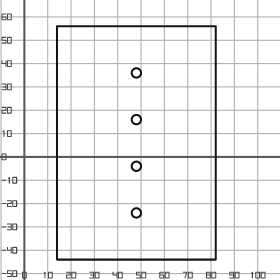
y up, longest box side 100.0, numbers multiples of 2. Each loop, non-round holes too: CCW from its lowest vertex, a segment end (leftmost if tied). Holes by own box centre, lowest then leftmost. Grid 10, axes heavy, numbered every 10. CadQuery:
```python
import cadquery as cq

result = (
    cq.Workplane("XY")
    .moveTo(14.0, -44.0)
    .lineTo(82.0, -44.0)
    .lineTo(82.0, 56.0)
    .lineTo(14.0, 56.0)
    .close()
    .moveTo(48.0, -24.0)
    .circle(2.0)
    .moveTo(48.0, -4.0)
    .circle(2.0)
    .moveTo(48.0, 16.0)
    .circle(2.0)
    .moveTo(48.0, 36.0)
    .circle(2.0)
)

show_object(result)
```